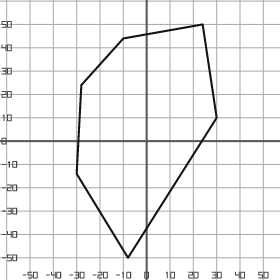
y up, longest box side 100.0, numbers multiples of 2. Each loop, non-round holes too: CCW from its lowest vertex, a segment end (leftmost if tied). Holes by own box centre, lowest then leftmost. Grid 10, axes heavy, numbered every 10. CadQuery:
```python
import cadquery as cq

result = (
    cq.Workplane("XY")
    .moveTo(-8.0, -50.0)
    .lineTo(30.0, 10.0)
    .lineTo(24.0, 50.0)
    .lineTo(-10.0, 44.0)
    .lineTo(-28.0, 24.0)
    .lineTo(-30.0, -14.0)
    .close()
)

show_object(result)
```